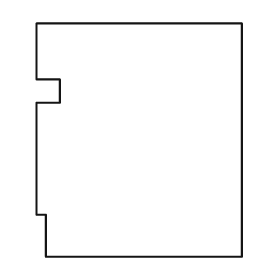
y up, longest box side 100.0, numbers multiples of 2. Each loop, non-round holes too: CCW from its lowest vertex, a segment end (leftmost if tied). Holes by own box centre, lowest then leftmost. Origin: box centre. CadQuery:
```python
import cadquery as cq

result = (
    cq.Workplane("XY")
    .moveTo(-40.0, -50.0)
    .lineTo(44.0, -50.0)
    .lineTo(44.0, 50.0)
    .lineTo(-44.0, 50.0)
    .lineTo(-44.0, 26.0)
    .lineTo(-34.0, 26.0)
    .lineTo(-34.0, 16.0)
    .lineTo(-44.0, 16.0)
    .lineTo(-44.0, -32.0)
    .lineTo(-40.0, -32.0)
    .close()
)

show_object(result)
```